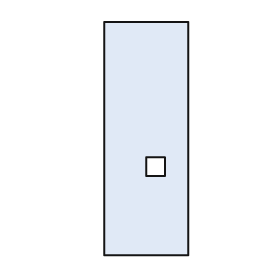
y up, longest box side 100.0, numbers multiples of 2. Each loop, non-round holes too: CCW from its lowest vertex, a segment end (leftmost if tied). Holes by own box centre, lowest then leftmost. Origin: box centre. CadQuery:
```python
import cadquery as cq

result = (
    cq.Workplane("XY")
    .moveTo(-18.0, -50.0)
    .lineTo(18.0, -50.0)
    .lineTo(18.0, 50.0)
    .lineTo(-18.0, 50.0)
    .close()
    .moveTo(0.0, -16.0)
    .lineTo(8.0, -16.0)
    .lineTo(8.0, -8.0)
    .lineTo(0.0, -8.0)
    .close()
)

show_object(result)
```